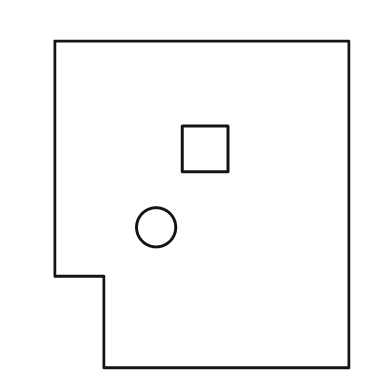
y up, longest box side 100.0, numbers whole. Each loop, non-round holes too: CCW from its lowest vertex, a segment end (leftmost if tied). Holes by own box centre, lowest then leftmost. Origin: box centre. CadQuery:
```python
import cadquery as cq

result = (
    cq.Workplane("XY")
    .moveTo(-30.0, -50.0)
    .lineTo(45.0, -50.0)
    .lineTo(45.0, 50.0)
    .lineTo(-45.0, 50.0)
    .lineTo(-45.0, -22.0)
    .lineTo(-30.0, -22.0)
    .close()
    .moveTo(-14.0, -7.0)
    .circle(6.0)
    .moveTo(-6.0, 10.0)
    .lineTo(8.0, 10.0)
    .lineTo(8.0, 24.0)
    .lineTo(-6.0, 24.0)
    .close()
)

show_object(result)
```